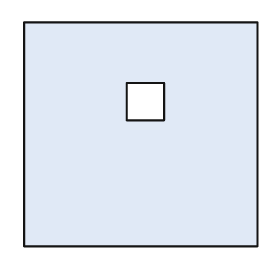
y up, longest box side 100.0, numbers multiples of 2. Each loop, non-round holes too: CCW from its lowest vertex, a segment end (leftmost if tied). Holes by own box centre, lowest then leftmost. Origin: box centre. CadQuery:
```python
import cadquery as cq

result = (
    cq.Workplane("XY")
    .moveTo(-50.0, -48.0)
    .lineTo(50.0, -48.0)
    .lineTo(50.0, 48.0)
    .lineTo(-50.0, 48.0)
    .close()
    .moveTo(-6.0, 6.0)
    .lineTo(10.0, 6.0)
    .lineTo(10.0, 22.0)
    .lineTo(-6.0, 22.0)
    .close()
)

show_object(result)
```